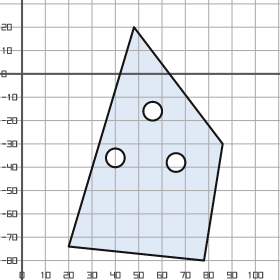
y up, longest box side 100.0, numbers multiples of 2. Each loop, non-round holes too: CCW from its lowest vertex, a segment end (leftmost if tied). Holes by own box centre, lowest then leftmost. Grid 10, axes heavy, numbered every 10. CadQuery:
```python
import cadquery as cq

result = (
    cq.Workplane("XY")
    .moveTo(78.0, -80.0)
    .lineTo(86.0, -30.0)
    .lineTo(48.0, 20.0)
    .lineTo(20.0, -74.0)
    .close()
    .moveTo(66.0, -38.0)
    .circle(4.0)
    .moveTo(40.0, -36.0)
    .circle(4.0)
    .moveTo(56.0, -16.0)
    .circle(4.0)
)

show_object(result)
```